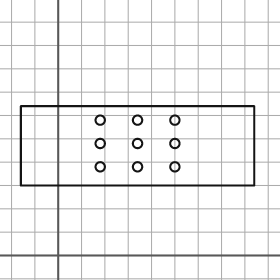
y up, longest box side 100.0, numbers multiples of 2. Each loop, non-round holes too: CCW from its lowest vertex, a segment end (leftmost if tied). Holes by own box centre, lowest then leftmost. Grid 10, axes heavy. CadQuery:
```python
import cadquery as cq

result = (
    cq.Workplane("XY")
    .moveTo(-16.0, 30.0)
    .lineTo(84.0, 30.0)
    .lineTo(84.0, 64.0)
    .lineTo(-16.0, 64.0)
    .close()
    .moveTo(18.0, 38.0)
    .circle(2.0)
    .moveTo(34.0, 38.0)
    .circle(2.0)
    .moveTo(50.0, 38.0)
    .circle(2.0)
    .moveTo(18.0, 48.0)
    .circle(2.0)
    .moveTo(34.0, 48.0)
    .circle(2.0)
    .moveTo(50.0, 48.0)
    .circle(2.0)
    .moveTo(18.0, 58.0)
    .circle(2.0)
    .moveTo(34.0, 58.0)
    .circle(2.0)
    .moveTo(50.0, 58.0)
    .circle(2.0)
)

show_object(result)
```